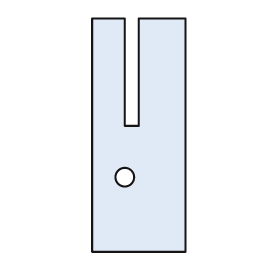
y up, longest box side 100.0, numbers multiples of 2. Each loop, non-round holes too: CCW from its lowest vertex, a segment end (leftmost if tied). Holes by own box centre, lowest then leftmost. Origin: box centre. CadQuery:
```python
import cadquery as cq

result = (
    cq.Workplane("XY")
    .moveTo(-20.0, -50.0)
    .lineTo(20.0, -50.0)
    .lineTo(20.0, 50.0)
    .lineTo(0.0, 50.0)
    .lineTo(0.0, 4.0)
    .lineTo(-6.0, 4.0)
    .lineTo(-6.0, 50.0)
    .lineTo(-20.0, 50.0)
    .close()
    .moveTo(-6.0, -18.0)
    .circle(4.0)
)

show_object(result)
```